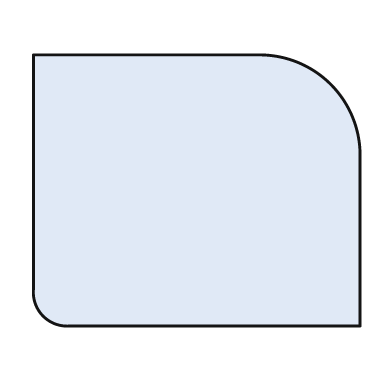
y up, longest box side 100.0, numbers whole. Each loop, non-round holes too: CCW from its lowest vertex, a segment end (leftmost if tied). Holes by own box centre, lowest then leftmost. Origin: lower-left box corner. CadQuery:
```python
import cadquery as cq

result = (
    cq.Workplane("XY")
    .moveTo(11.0, 0.0)
    .lineTo(100.0, 0.0)
    .lineTo(100.0, 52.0)
    .threePointArc((91.0, 74.0), (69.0, 83.0))
    .lineTo(0.0, 83.0)
    .lineTo(0.0, 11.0)
    .threePointArc((3.0, 3.0), (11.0, 0.0))
    .close()
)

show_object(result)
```